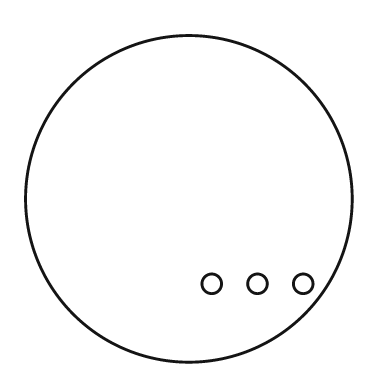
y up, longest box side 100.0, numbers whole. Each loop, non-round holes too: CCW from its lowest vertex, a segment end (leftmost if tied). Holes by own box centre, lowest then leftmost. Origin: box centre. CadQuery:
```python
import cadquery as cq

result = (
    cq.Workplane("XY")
    .moveTo(0.0, 0.0)
    .circle(50.0)
    .moveTo(7.0, -26.0)
    .circle(3.0)
    .moveTo(21.0, -26.0)
    .circle(3.0)
    .moveTo(35.0, -26.0)
    .circle(3.0)
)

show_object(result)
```